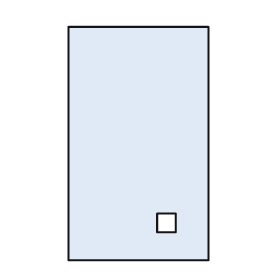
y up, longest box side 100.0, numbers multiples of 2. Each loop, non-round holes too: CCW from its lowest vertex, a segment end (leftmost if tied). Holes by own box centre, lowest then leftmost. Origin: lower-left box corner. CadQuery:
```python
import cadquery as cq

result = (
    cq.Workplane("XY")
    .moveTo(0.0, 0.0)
    .lineTo(60.0, 0.0)
    .lineTo(60.0, 100.0)
    .lineTo(0.0, 100.0)
    .close()
    .moveTo(38.0, 12.0)
    .lineTo(46.0, 12.0)
    .lineTo(46.0, 20.0)
    .lineTo(38.0, 20.0)
    .close()
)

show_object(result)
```